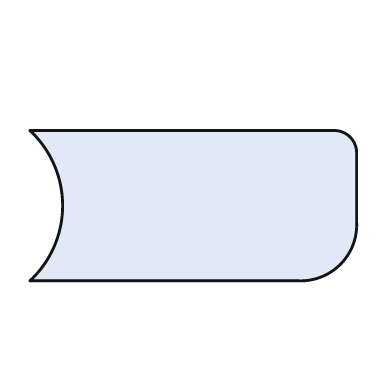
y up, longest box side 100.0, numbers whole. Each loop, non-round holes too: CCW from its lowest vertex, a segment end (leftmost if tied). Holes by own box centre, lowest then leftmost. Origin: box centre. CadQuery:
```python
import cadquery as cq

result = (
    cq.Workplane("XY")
    .moveTo(-50.0, -23.0)
    .lineTo(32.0, -23.0)
    .threePointArc((45.0, -18.0), (50.0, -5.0))
    .lineTo(50.0, 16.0)
    .threePointArc((48.0, 21.0), (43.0, 23.0))
    .lineTo(-50.0, 23.0)
    .threePointArc((-40.0, 0.0), (-50.0, -23.0))
    .close()
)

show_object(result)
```